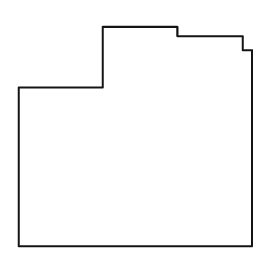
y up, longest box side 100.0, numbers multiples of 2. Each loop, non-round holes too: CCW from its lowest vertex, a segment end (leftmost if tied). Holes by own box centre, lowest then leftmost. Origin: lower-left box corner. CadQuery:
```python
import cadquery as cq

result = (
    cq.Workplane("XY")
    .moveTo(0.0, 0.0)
    .lineTo(100.0, 0.0)
    .lineTo(100.0, 84.0)
    .lineTo(96.0, 84.0)
    .lineTo(96.0, 90.0)
    .lineTo(68.0, 90.0)
    .lineTo(68.0, 94.0)
    .lineTo(36.0, 94.0)
    .lineTo(36.0, 68.0)
    .lineTo(0.0, 68.0)
    .close()
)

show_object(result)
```